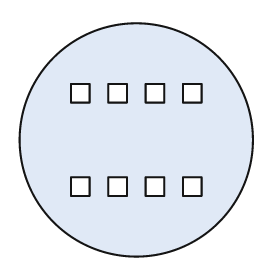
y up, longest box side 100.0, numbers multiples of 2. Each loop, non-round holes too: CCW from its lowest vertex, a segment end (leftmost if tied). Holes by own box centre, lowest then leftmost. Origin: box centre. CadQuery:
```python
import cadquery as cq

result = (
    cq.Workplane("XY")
    .moveTo(0.0, 0.0)
    .circle(50.0)
    .moveTo(-28.0, -24.0)
    .lineTo(-20.0, -24.0)
    .lineTo(-20.0, -16.0)
    .lineTo(-28.0, -16.0)
    .close()
    .moveTo(-12.0, -24.0)
    .lineTo(-4.0, -24.0)
    .lineTo(-4.0, -16.0)
    .lineTo(-12.0, -16.0)
    .close()
    .moveTo(4.0, -24.0)
    .lineTo(12.0, -24.0)
    .lineTo(12.0, -16.0)
    .lineTo(4.0, -16.0)
    .close()
    .moveTo(20.0, -24.0)
    .lineTo(28.0, -24.0)
    .lineTo(28.0, -16.0)
    .lineTo(20.0, -16.0)
    .close()
    .moveTo(-28.0, 16.0)
    .lineTo(-20.0, 16.0)
    .lineTo(-20.0, 24.0)
    .lineTo(-28.0, 24.0)
    .close()
    .moveTo(-12.0, 16.0)
    .lineTo(-4.0, 16.0)
    .lineTo(-4.0, 24.0)
    .lineTo(-12.0, 24.0)
    .close()
    .moveTo(4.0, 16.0)
    .lineTo(12.0, 16.0)
    .lineTo(12.0, 24.0)
    .lineTo(4.0, 24.0)
    .close()
    .moveTo(20.0, 16.0)
    .lineTo(28.0, 16.0)
    .lineTo(28.0, 24.0)
    .lineTo(20.0, 24.0)
    .close()
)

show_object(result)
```